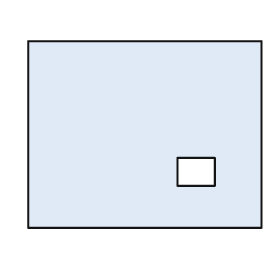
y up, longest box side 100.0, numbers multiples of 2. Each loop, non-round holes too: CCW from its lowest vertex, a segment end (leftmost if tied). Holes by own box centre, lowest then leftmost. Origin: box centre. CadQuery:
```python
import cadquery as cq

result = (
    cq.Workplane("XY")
    .moveTo(-50.0, -40.0)
    .lineTo(50.0, -40.0)
    .lineTo(50.0, 40.0)
    .lineTo(-50.0, 40.0)
    .close()
    .moveTo(14.0, -22.0)
    .lineTo(30.0, -22.0)
    .lineTo(30.0, -10.0)
    .lineTo(14.0, -10.0)
    .close()
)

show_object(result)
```